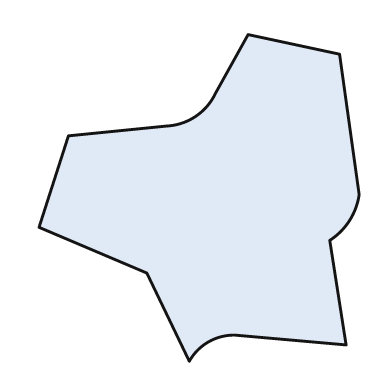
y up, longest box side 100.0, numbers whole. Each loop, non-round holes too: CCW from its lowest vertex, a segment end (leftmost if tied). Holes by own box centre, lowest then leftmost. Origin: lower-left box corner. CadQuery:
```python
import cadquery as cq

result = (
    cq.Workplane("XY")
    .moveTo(46.0, 0.0)
    .threePointArc((52.0, 6.0), (60.0, 8.0))
    .lineTo(94.0, 5.0)
    .lineTo(89.0, 37.0)
    .threePointArc((95.0, 43.0), (98.0, 51.0))
    .lineTo(92.0, 94.0)
    .lineTo(64.0, 100.0)
    .lineTo(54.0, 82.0)
    .threePointArc((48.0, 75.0), (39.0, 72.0))
    .lineTo(9.0, 69.0)
    .lineTo(0.0, 41.0)
    .lineTo(33.0, 27.0)
    .close()
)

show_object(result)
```